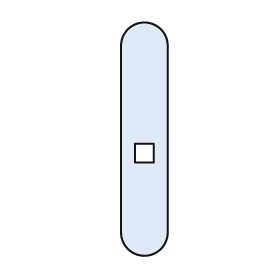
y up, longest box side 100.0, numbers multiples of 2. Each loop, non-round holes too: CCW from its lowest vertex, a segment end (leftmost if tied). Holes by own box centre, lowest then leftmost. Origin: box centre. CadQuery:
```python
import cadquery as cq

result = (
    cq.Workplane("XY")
    .moveTo(-10.0, -40.0)
    .threePointArc((0.0, -50.0), (10.0, -40.0))
    .lineTo(10.0, 40.0)
    .threePointArc((0.0, 50.0), (-10.0, 40.0))
    .close()
    .moveTo(-4.0, -10.0)
    .lineTo(4.0, -10.0)
    .lineTo(4.0, -2.0)
    .lineTo(-4.0, -2.0)
    .close()
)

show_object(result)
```